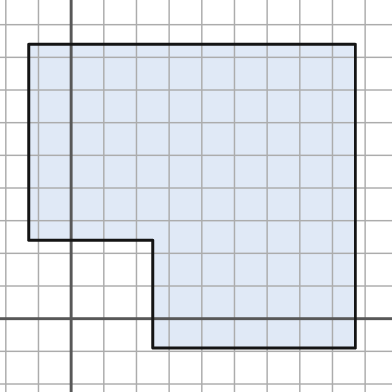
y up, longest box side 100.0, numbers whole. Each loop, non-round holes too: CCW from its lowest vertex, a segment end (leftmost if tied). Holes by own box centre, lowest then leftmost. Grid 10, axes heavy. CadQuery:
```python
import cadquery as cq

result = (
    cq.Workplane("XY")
    .moveTo(25.0, -9.0)
    .lineTo(87.0, -9.0)
    .lineTo(87.0, 84.0)
    .lineTo(-13.0, 84.0)
    .lineTo(-13.0, 24.0)
    .lineTo(25.0, 24.0)
    .close()
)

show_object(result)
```